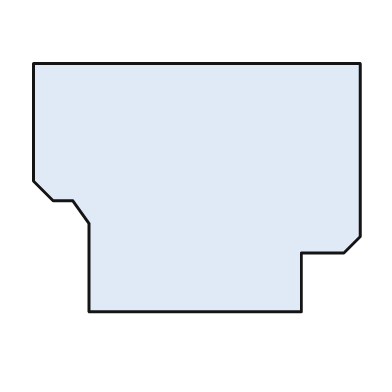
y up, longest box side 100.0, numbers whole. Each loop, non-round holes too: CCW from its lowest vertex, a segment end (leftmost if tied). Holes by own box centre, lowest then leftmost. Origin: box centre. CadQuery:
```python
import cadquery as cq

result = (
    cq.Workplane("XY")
    .moveTo(-33.0, -38.0)
    .lineTo(32.0, -38.0)
    .lineTo(32.0, -20.0)
    .lineTo(45.0, -20.0)
    .lineTo(50.0, -15.0)
    .lineTo(50.0, 38.0)
    .lineTo(-50.0, 38.0)
    .lineTo(-50.0, 2.0)
    .lineTo(-44.0, -4.0)
    .lineTo(-38.0, -4.0)
    .lineTo(-33.0, -11.0)
    .close()
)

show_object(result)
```